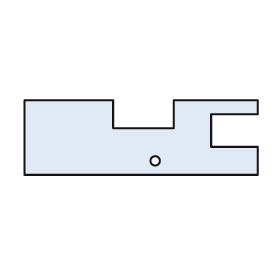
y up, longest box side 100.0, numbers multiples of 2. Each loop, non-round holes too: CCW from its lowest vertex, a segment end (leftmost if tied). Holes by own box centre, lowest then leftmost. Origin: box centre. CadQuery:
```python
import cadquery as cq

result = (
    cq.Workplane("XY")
    .moveTo(-50.0, -16.0)
    .lineTo(50.0, -16.0)
    .lineTo(50.0, -4.0)
    .lineTo(30.0, -4.0)
    .lineTo(30.0, 10.0)
    .lineTo(50.0, 10.0)
    .lineTo(50.0, 16.0)
    .lineTo(14.0, 16.0)
    .lineTo(14.0, 4.0)
    .lineTo(-12.0, 4.0)
    .lineTo(-12.0, 16.0)
    .lineTo(-50.0, 16.0)
    .close()
    .moveTo(6.0, -10.0)
    .circle(2.0)
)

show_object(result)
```